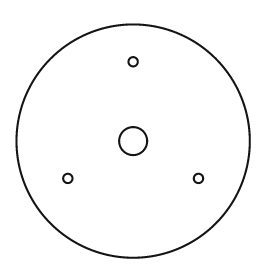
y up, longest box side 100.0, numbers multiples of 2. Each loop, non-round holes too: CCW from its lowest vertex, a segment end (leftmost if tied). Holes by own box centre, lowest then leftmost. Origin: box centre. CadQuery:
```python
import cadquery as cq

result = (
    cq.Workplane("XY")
    .moveTo(0.0, 0.0)
    .circle(50.0)
    .moveTo(-28.0, -16.0)
    .circle(2.0)
    .moveTo(28.0, -16.0)
    .circle(2.0)
    .moveTo(0.0, 0.0)
    .circle(6.0)
    .moveTo(0.0, 34.0)
    .circle(2.0)
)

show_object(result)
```